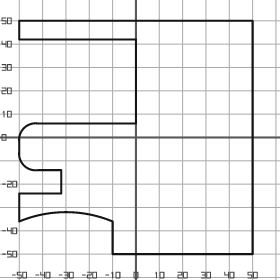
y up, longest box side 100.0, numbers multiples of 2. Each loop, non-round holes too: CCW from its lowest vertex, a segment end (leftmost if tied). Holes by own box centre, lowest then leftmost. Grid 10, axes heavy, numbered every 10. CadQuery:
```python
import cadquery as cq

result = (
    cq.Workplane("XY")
    .moveTo(-10.0, -50.0)
    .lineTo(50.0, -50.0)
    .lineTo(50.0, 50.0)
    .lineTo(-50.0, 50.0)
    .lineTo(-50.0, 42.0)
    .lineTo(0.0, 42.0)
    .lineTo(0.0, 6.0)
    .lineTo(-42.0, 6.0)
    .threePointArc((-48.0, 4.0), (-50.0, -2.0))
    .lineTo(-50.0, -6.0)
    .threePointArc((-48.0, -12.0), (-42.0, -14.0))
    .lineTo(-32.0, -14.0)
    .lineTo(-32.0, -24.0)
    .lineTo(-50.0, -24.0)
    .lineTo(-50.0, -36.0)
    .threePointArc((-30.0, -32.0), (-10.0, -36.0))
    .close()
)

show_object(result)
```